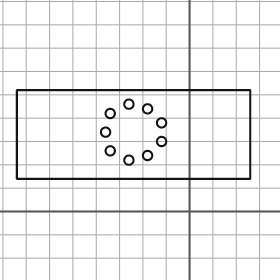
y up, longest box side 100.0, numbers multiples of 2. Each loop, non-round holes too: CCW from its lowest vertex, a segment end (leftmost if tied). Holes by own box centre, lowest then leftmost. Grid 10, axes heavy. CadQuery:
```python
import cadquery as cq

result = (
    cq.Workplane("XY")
    .moveTo(-74.0, 14.0)
    .lineTo(26.0, 14.0)
    .lineTo(26.0, 52.0)
    .lineTo(-74.0, 52.0)
    .close()
    .moveTo(-26.0, 22.0)
    .circle(2.0)
    .moveTo(-18.0, 24.0)
    .circle(2.0)
    .moveTo(-34.0, 26.0)
    .circle(2.0)
    .moveTo(-12.0, 30.0)
    .circle(2.0)
    .moveTo(-36.0, 34.0)
    .circle(2.0)
    .moveTo(-12.0, 38.0)
    .circle(2.0)
    .moveTo(-34.0, 42.0)
    .circle(2.0)
    .moveTo(-18.0, 44.0)
    .circle(2.0)
    .moveTo(-26.0, 46.0)
    .circle(2.0)
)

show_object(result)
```